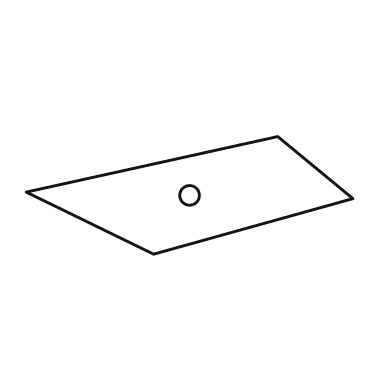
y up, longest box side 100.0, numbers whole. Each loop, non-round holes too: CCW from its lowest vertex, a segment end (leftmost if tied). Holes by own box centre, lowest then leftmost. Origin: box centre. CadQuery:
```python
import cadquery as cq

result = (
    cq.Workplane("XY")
    .moveTo(-11.0, -18.0)
    .lineTo(50.0, -1.0)
    .lineTo(27.0, 18.0)
    .lineTo(-50.0, 1.0)
    .close()
    .moveTo(0.0, 0.0)
    .circle(3.0)
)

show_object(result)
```